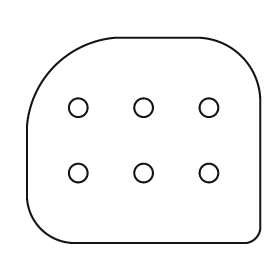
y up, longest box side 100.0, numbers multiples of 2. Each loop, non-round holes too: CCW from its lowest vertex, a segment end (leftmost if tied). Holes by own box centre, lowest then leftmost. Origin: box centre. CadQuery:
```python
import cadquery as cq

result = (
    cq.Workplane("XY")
    .moveTo(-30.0, -44.0)
    .lineTo(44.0, -44.0)
    .threePointArc((48.0, -42.0), (50.0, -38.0))
    .lineTo(50.0, 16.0)
    .threePointArc((42.0, 36.0), (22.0, 44.0))
    .lineTo(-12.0, 44.0)
    .threePointArc((-38.0, 32.0), (-50.0, 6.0))
    .lineTo(-50.0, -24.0)
    .threePointArc((-44.0, -38.0), (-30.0, -44.0))
    .close()
    .moveTo(-28.0, -14.0)
    .circle(4.0)
    .moveTo(0.0, -14.0)
    .circle(4.0)
    .moveTo(28.0, -14.0)
    .circle(4.0)
    .moveTo(-28.0, 14.0)
    .circle(4.0)
    .moveTo(0.0, 14.0)
    .circle(4.0)
    .moveTo(28.0, 14.0)
    .circle(4.0)
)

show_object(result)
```